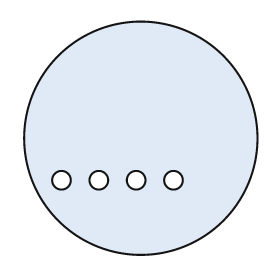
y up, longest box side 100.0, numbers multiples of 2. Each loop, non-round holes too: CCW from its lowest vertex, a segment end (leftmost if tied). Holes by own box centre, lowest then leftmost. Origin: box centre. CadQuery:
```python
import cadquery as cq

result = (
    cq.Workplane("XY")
    .moveTo(0.0, 0.0)
    .circle(50.0)
    .moveTo(-34.0, -18.0)
    .circle(4.0)
    .moveTo(-18.0, -18.0)
    .circle(4.0)
    .moveTo(-2.0, -18.0)
    .circle(4.0)
    .moveTo(14.0, -18.0)
    .circle(4.0)
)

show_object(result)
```